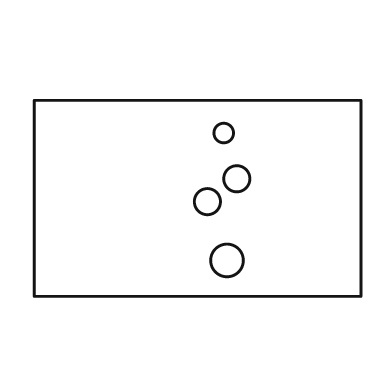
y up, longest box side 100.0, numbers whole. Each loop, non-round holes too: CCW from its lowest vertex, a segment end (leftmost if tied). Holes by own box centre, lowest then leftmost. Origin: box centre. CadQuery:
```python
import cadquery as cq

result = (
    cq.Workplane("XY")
    .moveTo(-50.0, -30.0)
    .lineTo(50.0, -30.0)
    .lineTo(50.0, 30.0)
    .lineTo(-50.0, 30.0)
    .close()
    .moveTo(9.0, -19.0)
    .circle(5.0)
    .moveTo(3.0, -1.0)
    .circle(4.0)
    .moveTo(12.0, 6.0)
    .circle(4.0)
    .moveTo(8.0, 20.0)
    .circle(3.0)
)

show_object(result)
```